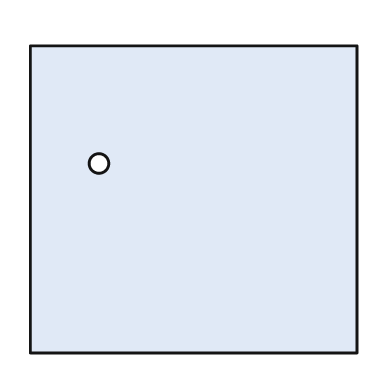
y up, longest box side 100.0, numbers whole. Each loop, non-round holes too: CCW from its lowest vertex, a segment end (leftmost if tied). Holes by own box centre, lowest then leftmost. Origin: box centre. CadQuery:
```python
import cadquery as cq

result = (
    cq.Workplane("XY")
    .moveTo(-50.0, -47.0)
    .lineTo(50.0, -47.0)
    .lineTo(50.0, 47.0)
    .lineTo(-50.0, 47.0)
    .close()
    .moveTo(-29.0, 11.0)
    .circle(3.0)
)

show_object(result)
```